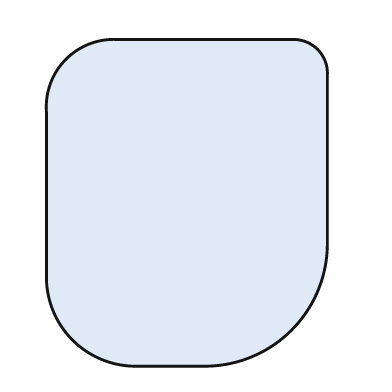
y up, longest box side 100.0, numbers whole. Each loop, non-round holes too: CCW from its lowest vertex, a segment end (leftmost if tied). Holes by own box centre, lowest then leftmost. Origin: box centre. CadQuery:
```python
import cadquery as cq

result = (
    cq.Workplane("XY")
    .moveTo(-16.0, -50.0)
    .lineTo(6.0, -50.0)
    .threePointArc((32.0, -39.0), (43.0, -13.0))
    .lineTo(43.0, 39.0)
    .threePointArc((40.0, 47.0), (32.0, 50.0))
    .lineTo(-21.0, 50.0)
    .threePointArc((-37.0, 44.0), (-43.0, 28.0))
    .lineTo(-43.0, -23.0)
    .threePointArc((-35.0, -42.0), (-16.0, -50.0))
    .close()
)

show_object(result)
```